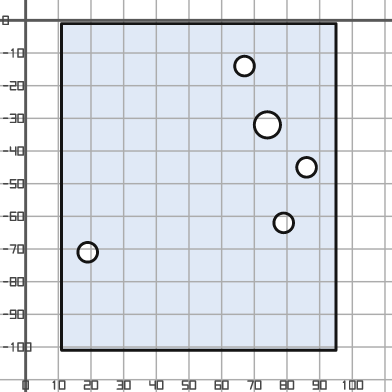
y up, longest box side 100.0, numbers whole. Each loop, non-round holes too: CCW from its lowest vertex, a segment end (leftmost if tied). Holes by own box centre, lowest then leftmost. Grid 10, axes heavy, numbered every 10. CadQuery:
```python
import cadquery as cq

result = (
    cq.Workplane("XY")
    .moveTo(11.0, -101.0)
    .lineTo(95.0, -101.0)
    .lineTo(95.0, -1.0)
    .lineTo(11.0, -1.0)
    .close()
    .moveTo(19.0, -71.0)
    .circle(3.0)
    .moveTo(79.0, -62.0)
    .circle(3.0)
    .moveTo(86.0, -45.0)
    .circle(3.0)
    .moveTo(74.0, -32.0)
    .circle(4.0)
    .moveTo(67.0, -14.0)
    .circle(3.0)
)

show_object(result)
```